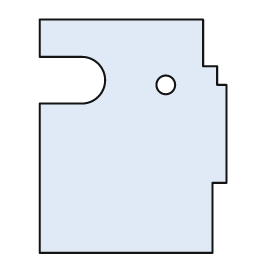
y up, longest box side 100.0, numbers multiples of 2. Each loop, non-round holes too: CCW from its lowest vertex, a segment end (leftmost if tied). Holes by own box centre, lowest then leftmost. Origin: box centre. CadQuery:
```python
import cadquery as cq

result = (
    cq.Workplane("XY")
    .moveTo(-40.0, -50.0)
    .lineTo(34.0, -50.0)
    .lineTo(34.0, -20.0)
    .lineTo(40.0, -20.0)
    .lineTo(40.0, 22.0)
    .lineTo(36.0, 22.0)
    .lineTo(36.0, 30.0)
    .lineTo(30.0, 30.0)
    .lineTo(30.0, 50.0)
    .lineTo(-40.0, 50.0)
    .lineTo(-40.0, 34.0)
    .lineTo(-22.0, 34.0)
    .threePointArc((-12.0, 24.0), (-22.0, 14.0))
    .lineTo(-40.0, 14.0)
    .close()
    .moveTo(14.0, 22.0)
    .circle(4.0)
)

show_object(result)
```